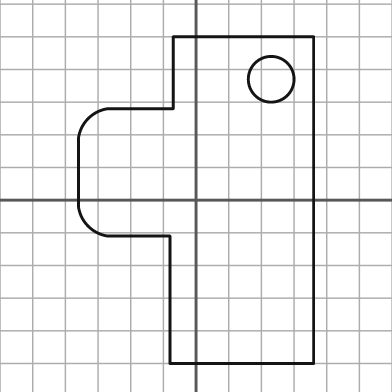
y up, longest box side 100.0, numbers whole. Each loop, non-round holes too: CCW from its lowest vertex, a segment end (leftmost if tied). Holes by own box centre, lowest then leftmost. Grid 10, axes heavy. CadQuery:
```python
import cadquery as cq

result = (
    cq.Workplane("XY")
    .moveTo(-8.0, -50.0)
    .lineTo(36.0, -50.0)
    .lineTo(36.0, 50.0)
    .lineTo(-7.0, 50.0)
    .lineTo(-7.0, 28.0)
    .lineTo(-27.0, 28.0)
    .threePointArc((-33.0, 25.0), (-36.0, 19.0))
    .lineTo(-36.0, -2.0)
    .threePointArc((-33.0, -8.0), (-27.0, -11.0))
    .lineTo(-8.0, -11.0)
    .close()
    .moveTo(23.0, 37.0)
    .circle(7.0)
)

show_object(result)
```